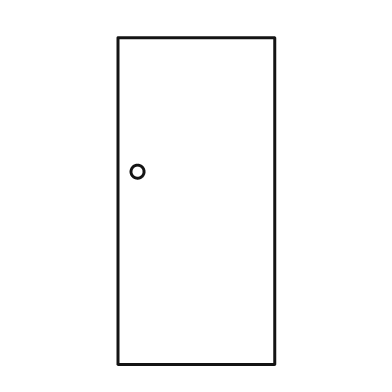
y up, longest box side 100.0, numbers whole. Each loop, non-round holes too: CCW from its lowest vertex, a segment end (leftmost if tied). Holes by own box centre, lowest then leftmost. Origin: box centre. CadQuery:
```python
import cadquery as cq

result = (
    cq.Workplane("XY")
    .moveTo(-24.0, -50.0)
    .lineTo(24.0, -50.0)
    .lineTo(24.0, 50.0)
    .lineTo(-24.0, 50.0)
    .close()
    .moveTo(-18.0, 9.0)
    .circle(2.0)
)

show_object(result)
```